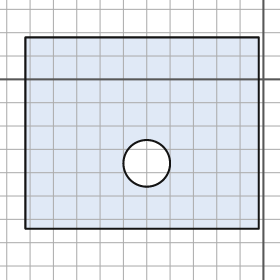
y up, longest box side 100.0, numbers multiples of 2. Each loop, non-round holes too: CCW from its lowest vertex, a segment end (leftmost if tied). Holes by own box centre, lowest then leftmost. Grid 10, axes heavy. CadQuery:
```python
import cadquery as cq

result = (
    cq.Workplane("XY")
    .moveTo(-102.0, -64.0)
    .lineTo(-2.0, -64.0)
    .lineTo(-2.0, 18.0)
    .lineTo(-102.0, 18.0)
    .close()
    .moveTo(-50.0, -36.0)
    .circle(10.0)
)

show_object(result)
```